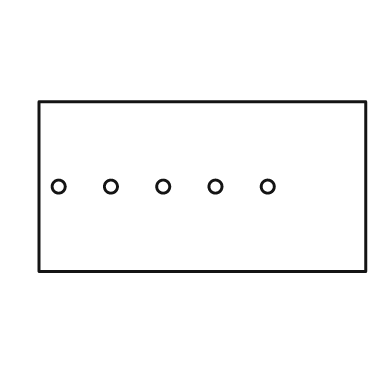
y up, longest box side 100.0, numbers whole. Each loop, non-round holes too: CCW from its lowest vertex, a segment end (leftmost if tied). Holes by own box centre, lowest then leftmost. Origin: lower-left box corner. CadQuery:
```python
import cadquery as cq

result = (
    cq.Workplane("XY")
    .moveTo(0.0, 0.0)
    .lineTo(100.0, 0.0)
    .lineTo(100.0, 52.0)
    .lineTo(0.0, 52.0)
    .close()
    .moveTo(6.0, 26.0)
    .circle(2.0)
    .moveTo(22.0, 26.0)
    .circle(2.0)
    .moveTo(38.0, 26.0)
    .circle(2.0)
    .moveTo(54.0, 26.0)
    .circle(2.0)
    .moveTo(70.0, 26.0)
    .circle(2.0)
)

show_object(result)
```